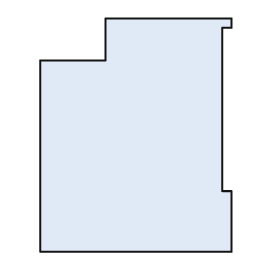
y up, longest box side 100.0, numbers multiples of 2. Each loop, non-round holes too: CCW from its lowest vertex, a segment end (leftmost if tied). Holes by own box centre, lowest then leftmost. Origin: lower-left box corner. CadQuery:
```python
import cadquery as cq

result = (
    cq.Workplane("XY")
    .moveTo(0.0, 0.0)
    .lineTo(82.0, 0.0)
    .lineTo(82.0, 26.0)
    .lineTo(78.0, 26.0)
    .lineTo(78.0, 96.0)
    .lineTo(82.0, 96.0)
    .lineTo(82.0, 100.0)
    .lineTo(28.0, 100.0)
    .lineTo(28.0, 82.0)
    .lineTo(0.0, 82.0)
    .close()
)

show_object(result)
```